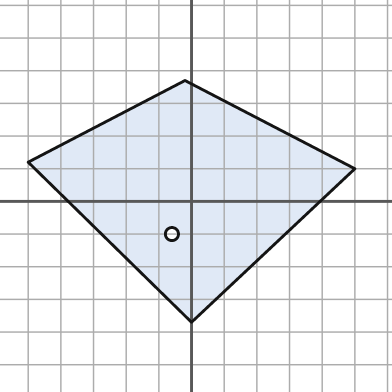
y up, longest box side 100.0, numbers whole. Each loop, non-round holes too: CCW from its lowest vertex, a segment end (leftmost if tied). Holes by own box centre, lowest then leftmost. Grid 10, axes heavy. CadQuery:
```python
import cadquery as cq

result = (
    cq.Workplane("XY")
    .moveTo(0.0, -37.0)
    .lineTo(50.0, 10.0)
    .lineTo(-2.0, 37.0)
    .lineTo(-50.0, 12.0)
    .close()
    .moveTo(-6.0, -10.0)
    .circle(2.0)
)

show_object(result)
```